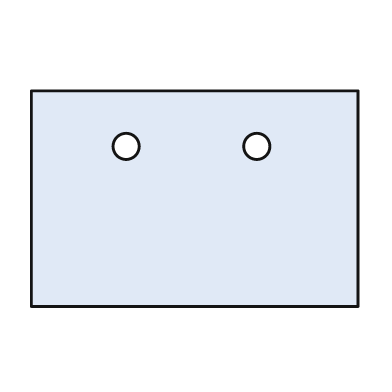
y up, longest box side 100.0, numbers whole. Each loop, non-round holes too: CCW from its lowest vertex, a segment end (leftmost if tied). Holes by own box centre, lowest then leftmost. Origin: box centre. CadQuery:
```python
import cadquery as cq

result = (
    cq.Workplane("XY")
    .moveTo(-50.0, -33.0)
    .lineTo(50.0, -33.0)
    .lineTo(50.0, 33.0)
    .lineTo(-50.0, 33.0)
    .close()
    .moveTo(-21.0, 16.0)
    .circle(4.0)
    .moveTo(19.0, 16.0)
    .circle(4.0)
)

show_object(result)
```